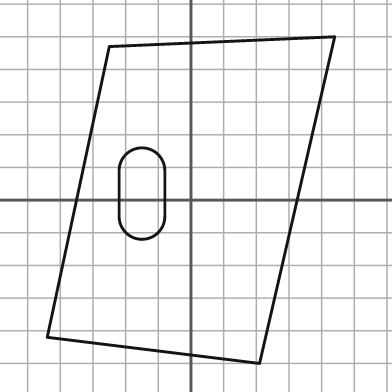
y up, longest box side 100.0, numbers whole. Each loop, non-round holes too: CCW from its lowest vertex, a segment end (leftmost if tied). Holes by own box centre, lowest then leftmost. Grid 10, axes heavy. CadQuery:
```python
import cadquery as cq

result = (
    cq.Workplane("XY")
    .moveTo(21.0, -50.0)
    .lineTo(44.0, 50.0)
    .lineTo(-25.0, 47.0)
    .lineTo(-44.0, -42.0)
    .close()
    .moveTo(-22.0, -5.0)
    .threePointArc((-15.0, -12.0), (-8.0, -5.0))
    .lineTo(-8.0, 9.0)
    .threePointArc((-15.0, 16.0), (-22.0, 9.0))
    .close()
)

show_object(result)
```